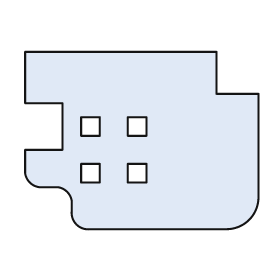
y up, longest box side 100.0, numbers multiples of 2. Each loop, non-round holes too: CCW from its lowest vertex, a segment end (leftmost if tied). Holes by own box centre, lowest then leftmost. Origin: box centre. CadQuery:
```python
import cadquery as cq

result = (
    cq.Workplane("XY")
    .moveTo(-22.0, -38.0)
    .lineTo(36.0, -38.0)
    .threePointArc((46.0, -34.0), (50.0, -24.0))
    .lineTo(50.0, 20.0)
    .lineTo(32.0, 20.0)
    .lineTo(32.0, 38.0)
    .lineTo(-50.0, 38.0)
    .lineTo(-50.0, 16.0)
    .lineTo(-34.0, 16.0)
    .lineTo(-34.0, -4.0)
    .lineTo(-50.0, -4.0)
    .lineTo(-50.0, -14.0)
    .threePointArc((-48.0, -18.0), (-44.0, -20.0))
    .lineTo(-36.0, -20.0)
    .threePointArc((-32.0, -22.0), (-30.0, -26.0))
    .lineTo(-30.0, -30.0)
    .threePointArc((-28.0, -36.0), (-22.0, -38.0))
    .close()
    .moveTo(-26.0, -18.0)
    .lineTo(-18.0, -18.0)
    .lineTo(-18.0, -10.0)
    .lineTo(-26.0, -10.0)
    .close()
    .moveTo(-6.0, -18.0)
    .lineTo(2.0, -18.0)
    .lineTo(2.0, -10.0)
    .lineTo(-6.0, -10.0)
    .close()
    .moveTo(-26.0, 2.0)
    .lineTo(-18.0, 2.0)
    .lineTo(-18.0, 10.0)
    .lineTo(-26.0, 10.0)
    .close()
    .moveTo(-6.0, 2.0)
    .lineTo(2.0, 2.0)
    .lineTo(2.0, 10.0)
    .lineTo(-6.0, 10.0)
    .close()
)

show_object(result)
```